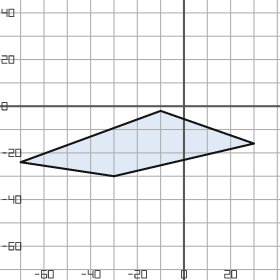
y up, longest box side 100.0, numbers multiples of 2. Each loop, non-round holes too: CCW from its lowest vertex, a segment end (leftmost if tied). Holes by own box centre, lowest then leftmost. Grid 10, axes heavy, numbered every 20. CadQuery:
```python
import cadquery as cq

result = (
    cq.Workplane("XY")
    .moveTo(-30.0, -30.0)
    .lineTo(30.0, -16.0)
    .lineTo(-10.0, -2.0)
    .lineTo(-70.0, -24.0)
    .close()
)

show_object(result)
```